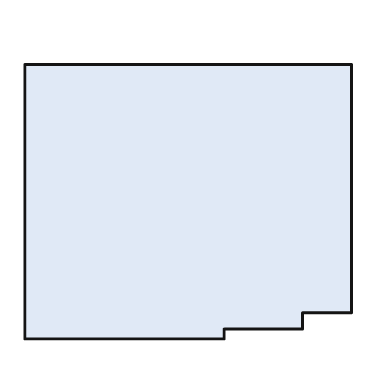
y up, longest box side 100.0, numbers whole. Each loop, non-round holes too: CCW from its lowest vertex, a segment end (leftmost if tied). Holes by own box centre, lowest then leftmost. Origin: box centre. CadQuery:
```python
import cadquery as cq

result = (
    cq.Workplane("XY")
    .moveTo(-50.0, -42.0)
    .lineTo(11.0, -42.0)
    .lineTo(11.0, -39.0)
    .lineTo(35.0, -39.0)
    .lineTo(35.0, -34.0)
    .lineTo(50.0, -34.0)
    .lineTo(50.0, 42.0)
    .lineTo(-50.0, 42.0)
    .close()
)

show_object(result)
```